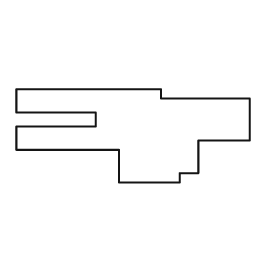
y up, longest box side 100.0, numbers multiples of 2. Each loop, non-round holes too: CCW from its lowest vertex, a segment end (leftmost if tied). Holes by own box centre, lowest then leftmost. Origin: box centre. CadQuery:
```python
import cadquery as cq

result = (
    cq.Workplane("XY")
    .moveTo(-6.0, -20.0)
    .lineTo(20.0, -20.0)
    .lineTo(20.0, -16.0)
    .lineTo(28.0, -16.0)
    .lineTo(28.0, -2.0)
    .lineTo(50.0, -2.0)
    .lineTo(50.0, 16.0)
    .lineTo(12.0, 16.0)
    .lineTo(12.0, 20.0)
    .lineTo(-50.0, 20.0)
    .lineTo(-50.0, 10.0)
    .lineTo(-16.0, 10.0)
    .lineTo(-16.0, 4.0)
    .lineTo(-50.0, 4.0)
    .lineTo(-50.0, -6.0)
    .lineTo(-6.0, -6.0)
    .close()
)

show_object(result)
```